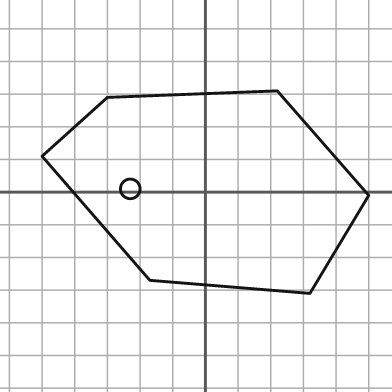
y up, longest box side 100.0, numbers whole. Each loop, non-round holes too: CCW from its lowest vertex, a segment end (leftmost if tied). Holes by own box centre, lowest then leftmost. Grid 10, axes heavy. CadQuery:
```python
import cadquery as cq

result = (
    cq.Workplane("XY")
    .moveTo(32.0, -31.0)
    .lineTo(50.0, -1.0)
    .lineTo(22.0, 31.0)
    .lineTo(-30.0, 29.0)
    .lineTo(-50.0, 11.0)
    .lineTo(-17.0, -27.0)
    .close()
    .moveTo(-23.0, 1.0)
    .circle(3.0)
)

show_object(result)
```